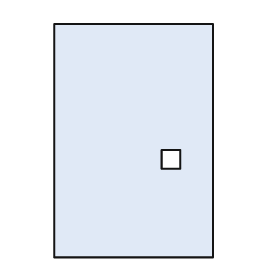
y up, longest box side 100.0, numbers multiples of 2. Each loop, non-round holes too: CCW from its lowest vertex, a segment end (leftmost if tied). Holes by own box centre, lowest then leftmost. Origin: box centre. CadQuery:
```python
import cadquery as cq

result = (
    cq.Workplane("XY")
    .moveTo(-34.0, -50.0)
    .lineTo(34.0, -50.0)
    .lineTo(34.0, 50.0)
    .lineTo(-34.0, 50.0)
    .close()
    .moveTo(12.0, -12.0)
    .lineTo(20.0, -12.0)
    .lineTo(20.0, -4.0)
    .lineTo(12.0, -4.0)
    .close()
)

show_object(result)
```